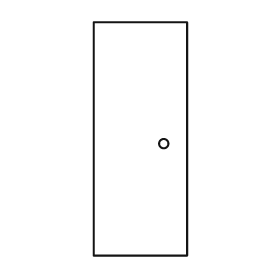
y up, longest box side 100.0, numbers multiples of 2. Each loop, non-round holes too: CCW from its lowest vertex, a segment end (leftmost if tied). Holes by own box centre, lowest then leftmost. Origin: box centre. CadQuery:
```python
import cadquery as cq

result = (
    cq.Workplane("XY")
    .moveTo(-20.0, -50.0)
    .lineTo(20.0, -50.0)
    .lineTo(20.0, 50.0)
    .lineTo(-20.0, 50.0)
    .close()
    .moveTo(10.0, -2.0)
    .circle(2.0)
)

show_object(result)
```